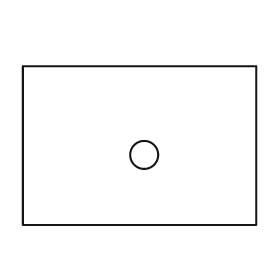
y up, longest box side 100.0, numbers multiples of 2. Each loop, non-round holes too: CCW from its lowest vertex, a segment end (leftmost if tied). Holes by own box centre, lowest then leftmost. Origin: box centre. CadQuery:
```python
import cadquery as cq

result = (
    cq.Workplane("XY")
    .moveTo(-50.0, -34.0)
    .lineTo(50.0, -34.0)
    .lineTo(50.0, 34.0)
    .lineTo(-50.0, 34.0)
    .close()
    .moveTo(2.0, -4.0)
    .circle(6.0)
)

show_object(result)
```